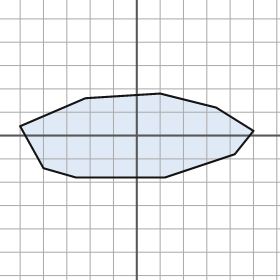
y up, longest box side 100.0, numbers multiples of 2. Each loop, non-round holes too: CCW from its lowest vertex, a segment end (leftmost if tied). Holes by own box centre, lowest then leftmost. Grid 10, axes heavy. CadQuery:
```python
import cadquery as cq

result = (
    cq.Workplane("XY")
    .moveTo(-26.0, -18.0)
    .lineTo(12.0, -18.0)
    .lineTo(42.0, -8.0)
    .lineTo(50.0, 2.0)
    .lineTo(34.0, 12.0)
    .lineTo(10.0, 18.0)
    .lineTo(-22.0, 16.0)
    .lineTo(-50.0, 4.0)
    .lineTo(-40.0, -14.0)
    .close()
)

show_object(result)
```